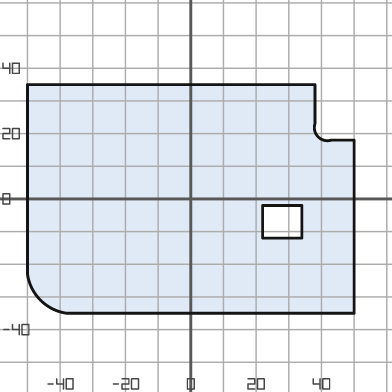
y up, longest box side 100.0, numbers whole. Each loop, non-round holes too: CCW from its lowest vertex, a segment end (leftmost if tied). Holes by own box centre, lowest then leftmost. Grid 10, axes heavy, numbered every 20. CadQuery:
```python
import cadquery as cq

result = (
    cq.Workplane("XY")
    .moveTo(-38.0, -35.0)
    .lineTo(50.0, -35.0)
    .lineTo(50.0, 18.0)
    .lineTo(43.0, 18.0)
    .threePointArc((39.0, 19.0), (38.0, 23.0))
    .lineTo(38.0, 35.0)
    .lineTo(-50.0, 35.0)
    .lineTo(-50.0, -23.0)
    .threePointArc((-46.0, -31.0), (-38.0, -35.0))
    .close()
    .moveTo(22.0, -12.0)
    .lineTo(34.0, -12.0)
    .lineTo(34.0, -2.0)
    .lineTo(22.0, -2.0)
    .close()
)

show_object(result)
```